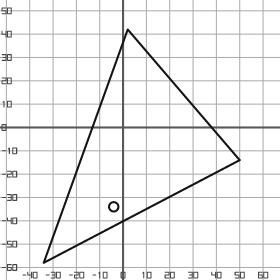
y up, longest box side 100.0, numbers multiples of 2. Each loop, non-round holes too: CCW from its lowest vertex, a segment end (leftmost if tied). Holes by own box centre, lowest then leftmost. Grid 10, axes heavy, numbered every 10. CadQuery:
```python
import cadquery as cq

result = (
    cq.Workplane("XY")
    .moveTo(-34.0, -58.0)
    .lineTo(50.0, -14.0)
    .lineTo(2.0, 42.0)
    .close()
    .moveTo(-4.0, -34.0)
    .circle(2.0)
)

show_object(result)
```